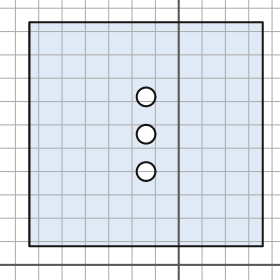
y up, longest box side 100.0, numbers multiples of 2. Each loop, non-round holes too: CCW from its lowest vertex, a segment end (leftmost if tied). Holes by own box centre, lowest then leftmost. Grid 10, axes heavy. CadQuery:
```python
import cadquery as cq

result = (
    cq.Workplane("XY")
    .moveTo(-64.0, 8.0)
    .lineTo(36.0, 8.0)
    .lineTo(36.0, 104.0)
    .lineTo(-64.0, 104.0)
    .close()
    .moveTo(-14.0, 40.0)
    .circle(4.0)
    .moveTo(-14.0, 56.0)
    .circle(4.0)
    .moveTo(-14.0, 72.0)
    .circle(4.0)
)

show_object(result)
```